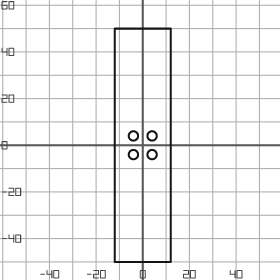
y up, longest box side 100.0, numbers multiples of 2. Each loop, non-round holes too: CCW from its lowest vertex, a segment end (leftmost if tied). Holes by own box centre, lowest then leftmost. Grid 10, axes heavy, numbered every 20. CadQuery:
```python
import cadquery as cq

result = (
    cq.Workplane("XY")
    .moveTo(-12.0, -50.0)
    .lineTo(12.0, -50.0)
    .lineTo(12.0, 50.0)
    .lineTo(-12.0, 50.0)
    .close()
    .moveTo(-4.0, -4.0)
    .circle(2.0)
    .moveTo(4.0, -4.0)
    .circle(2.0)
    .moveTo(-4.0, 4.0)
    .circle(2.0)
    .moveTo(4.0, 4.0)
    .circle(2.0)
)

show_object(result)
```